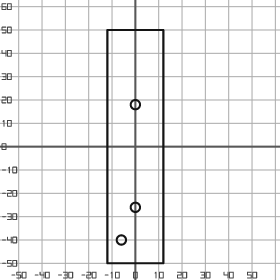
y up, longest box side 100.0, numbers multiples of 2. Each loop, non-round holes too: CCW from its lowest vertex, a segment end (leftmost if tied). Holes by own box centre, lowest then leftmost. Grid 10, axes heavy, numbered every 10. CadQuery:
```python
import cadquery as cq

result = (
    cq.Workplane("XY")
    .moveTo(-12.0, -50.0)
    .lineTo(12.0, -50.0)
    .lineTo(12.0, 50.0)
    .lineTo(-12.0, 50.0)
    .close()
    .moveTo(-6.0, -40.0)
    .circle(2.0)
    .moveTo(0.0, -26.0)
    .circle(2.0)
    .moveTo(0.0, 18.0)
    .circle(2.0)
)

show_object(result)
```